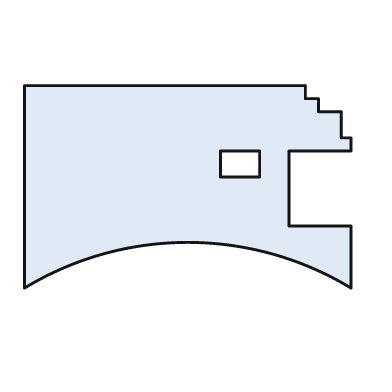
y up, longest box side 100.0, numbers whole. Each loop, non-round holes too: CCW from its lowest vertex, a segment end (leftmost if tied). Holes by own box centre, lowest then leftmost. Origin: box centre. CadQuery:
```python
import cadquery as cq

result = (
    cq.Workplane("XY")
    .moveTo(-50.0, -31.0)
    .threePointArc((0.0, -17.0), (50.0, -31.0))
    .lineTo(50.0, -12.0)
    .lineTo(31.0, -12.0)
    .lineTo(31.0, 11.0)
    .lineTo(50.0, 11.0)
    .lineTo(50.0, 15.0)
    .lineTo(47.0, 15.0)
    .lineTo(47.0, 23.0)
    .lineTo(40.0, 23.0)
    .lineTo(40.0, 27.0)
    .lineTo(36.0, 27.0)
    .lineTo(36.0, 31.0)
    .lineTo(-50.0, 31.0)
    .close()
    .moveTo(10.0, 3.0)
    .lineTo(22.0, 3.0)
    .lineTo(22.0, 11.0)
    .lineTo(10.0, 11.0)
    .close()
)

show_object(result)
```